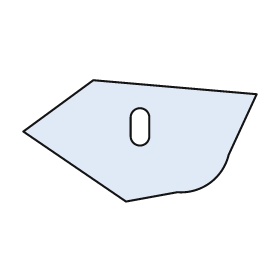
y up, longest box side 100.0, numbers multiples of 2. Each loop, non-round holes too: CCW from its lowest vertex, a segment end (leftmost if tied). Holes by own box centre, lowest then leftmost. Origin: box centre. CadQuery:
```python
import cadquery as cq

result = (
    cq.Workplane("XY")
    .moveTo(-6.0, -26.0)
    .lineTo(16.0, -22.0)
    .threePointArc((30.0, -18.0), (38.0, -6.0))
    .lineTo(50.0, 20.0)
    .lineTo(-20.0, 26.0)
    .lineTo(-50.0, 4.0)
    .close()
    .moveTo(-4.0, 2.0)
    .threePointArc((0.0, -2.0), (4.0, 2.0))
    .lineTo(4.0, 10.0)
    .threePointArc((0.0, 14.0), (-4.0, 10.0))
    .close()
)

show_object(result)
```